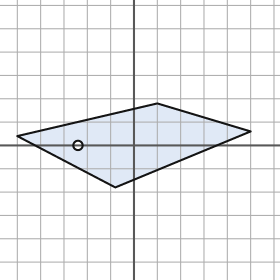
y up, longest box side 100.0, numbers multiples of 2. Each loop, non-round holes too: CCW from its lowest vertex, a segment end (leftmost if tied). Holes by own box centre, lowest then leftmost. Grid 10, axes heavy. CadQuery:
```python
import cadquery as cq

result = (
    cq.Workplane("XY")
    .moveTo(-8.0, -18.0)
    .lineTo(50.0, 6.0)
    .lineTo(10.0, 18.0)
    .lineTo(-50.0, 4.0)
    .close()
    .moveTo(-24.0, 0.0)
    .circle(2.0)
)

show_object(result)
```